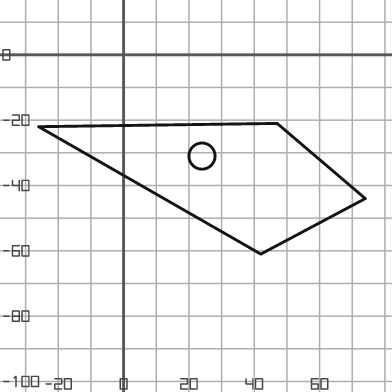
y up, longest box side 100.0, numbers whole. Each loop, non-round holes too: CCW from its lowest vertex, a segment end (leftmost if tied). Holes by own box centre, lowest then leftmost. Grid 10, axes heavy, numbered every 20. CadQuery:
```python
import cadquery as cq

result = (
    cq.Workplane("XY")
    .moveTo(42.0, -61.0)
    .lineTo(74.0, -44.0)
    .lineTo(47.0, -21.0)
    .lineTo(-26.0, -22.0)
    .close()
    .moveTo(24.0, -31.0)
    .circle(4.0)
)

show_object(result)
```